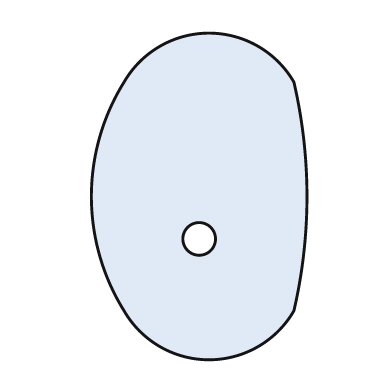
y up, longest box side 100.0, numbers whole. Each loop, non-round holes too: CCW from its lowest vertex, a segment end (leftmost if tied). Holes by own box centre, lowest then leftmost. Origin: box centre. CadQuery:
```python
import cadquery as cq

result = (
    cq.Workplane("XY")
    .moveTo(-23.0, -35.0)
    .threePointArc((3.0, -50.0), (29.0, -35.0))
    .threePointArc((33.0, 0.0), (29.0, 35.0))
    .threePointArc((3.0, 50.0), (-23.0, 35.0))
    .threePointArc((-33.0, 0.0), (-23.0, -35.0))
    .close()
    .moveTo(0.0, -13.0)
    .circle(5.0)
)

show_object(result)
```